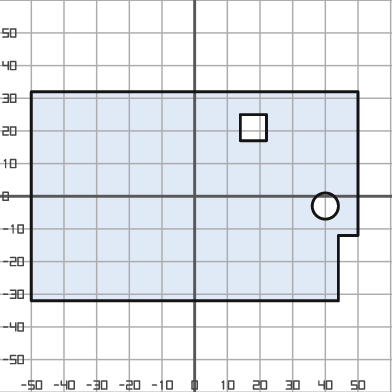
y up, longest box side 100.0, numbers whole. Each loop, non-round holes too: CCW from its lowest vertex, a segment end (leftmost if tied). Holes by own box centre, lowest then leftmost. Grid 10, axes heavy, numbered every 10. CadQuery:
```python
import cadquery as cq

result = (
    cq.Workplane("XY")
    .moveTo(-50.0, -32.0)
    .lineTo(44.0, -32.0)
    .lineTo(44.0, -12.0)
    .lineTo(50.0, -12.0)
    .lineTo(50.0, 32.0)
    .lineTo(-50.0, 32.0)
    .close()
    .moveTo(40.0, -3.0)
    .circle(4.0)
    .moveTo(14.0, 17.0)
    .lineTo(22.0, 17.0)
    .lineTo(22.0, 25.0)
    .lineTo(14.0, 25.0)
    .close()
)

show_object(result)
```